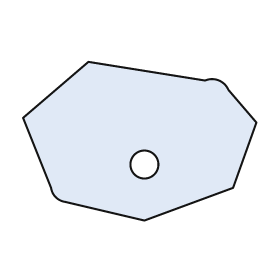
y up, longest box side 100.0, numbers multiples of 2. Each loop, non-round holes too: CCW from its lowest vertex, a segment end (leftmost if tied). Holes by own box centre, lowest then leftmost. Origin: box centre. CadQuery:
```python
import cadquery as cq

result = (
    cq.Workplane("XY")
    .moveTo(2.0, -34.0)
    .lineTo(40.0, -20.0)
    .lineTo(50.0, 8.0)
    .lineTo(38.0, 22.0)
    .threePointArc((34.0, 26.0), (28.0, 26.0))
    .lineTo(-22.0, 34.0)
    .lineTo(-50.0, 10.0)
    .lineTo(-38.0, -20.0)
    .threePointArc((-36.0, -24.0), (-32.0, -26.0))
    .close()
    .moveTo(2.0, -10.0)
    .circle(6.0)
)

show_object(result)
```